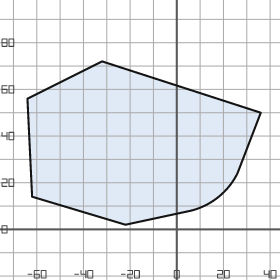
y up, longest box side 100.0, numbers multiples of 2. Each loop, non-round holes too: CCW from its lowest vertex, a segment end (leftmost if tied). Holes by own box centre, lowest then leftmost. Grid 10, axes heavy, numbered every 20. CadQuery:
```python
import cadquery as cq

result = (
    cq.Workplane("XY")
    .moveTo(-22.0, 2.0)
    .lineTo(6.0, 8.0)
    .threePointArc((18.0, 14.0), (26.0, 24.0))
    .lineTo(36.0, 50.0)
    .lineTo(-32.0, 72.0)
    .lineTo(-64.0, 56.0)
    .lineTo(-62.0, 14.0)
    .close()
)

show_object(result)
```